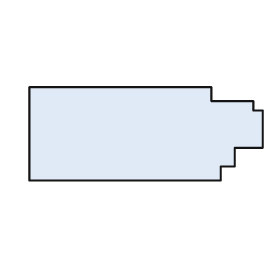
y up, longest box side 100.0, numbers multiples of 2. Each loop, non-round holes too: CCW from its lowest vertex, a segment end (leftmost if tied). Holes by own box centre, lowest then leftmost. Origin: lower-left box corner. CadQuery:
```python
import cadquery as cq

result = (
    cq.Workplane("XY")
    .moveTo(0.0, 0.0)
    .lineTo(82.0, 0.0)
    .lineTo(82.0, 6.0)
    .lineTo(88.0, 6.0)
    .lineTo(88.0, 14.0)
    .lineTo(100.0, 14.0)
    .lineTo(100.0, 30.0)
    .lineTo(96.0, 30.0)
    .lineTo(96.0, 34.0)
    .lineTo(78.0, 34.0)
    .lineTo(78.0, 40.0)
    .lineTo(0.0, 40.0)
    .close()
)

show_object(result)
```